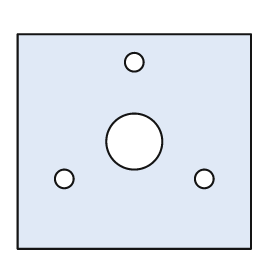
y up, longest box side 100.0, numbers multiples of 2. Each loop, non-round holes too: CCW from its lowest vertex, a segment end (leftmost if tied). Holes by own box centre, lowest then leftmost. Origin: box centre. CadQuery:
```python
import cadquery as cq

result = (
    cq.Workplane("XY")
    .moveTo(-50.0, -46.0)
    .lineTo(50.0, -46.0)
    .lineTo(50.0, 46.0)
    .lineTo(-50.0, 46.0)
    .close()
    .moveTo(-30.0, -16.0)
    .circle(4.0)
    .moveTo(30.0, -16.0)
    .circle(4.0)
    .moveTo(0.0, 0.0)
    .circle(12.0)
    .moveTo(0.0, 34.0)
    .circle(4.0)
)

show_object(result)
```